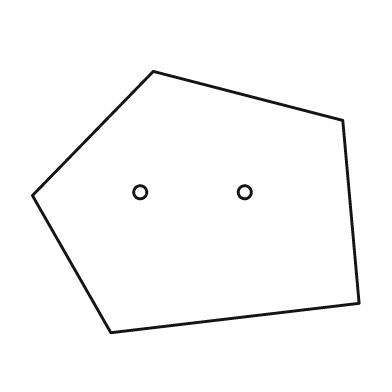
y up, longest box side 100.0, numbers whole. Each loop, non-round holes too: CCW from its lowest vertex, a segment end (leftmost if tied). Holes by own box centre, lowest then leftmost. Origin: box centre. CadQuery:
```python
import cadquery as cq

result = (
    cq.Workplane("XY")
    .moveTo(-26.0, -40.0)
    .lineTo(50.0, -31.0)
    .lineTo(45.0, 25.0)
    .lineTo(-13.0, 40.0)
    .lineTo(-50.0, 2.0)
    .close()
    .moveTo(-17.0, 3.0)
    .circle(2.0)
    .moveTo(15.0, 3.0)
    .circle(2.0)
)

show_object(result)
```